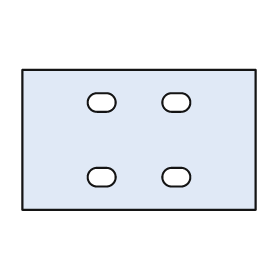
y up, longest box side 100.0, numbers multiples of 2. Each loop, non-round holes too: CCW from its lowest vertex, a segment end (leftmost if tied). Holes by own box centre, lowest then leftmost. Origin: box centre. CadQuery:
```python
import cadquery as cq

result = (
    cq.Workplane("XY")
    .moveTo(-50.0, -30.0)
    .lineTo(50.0, -30.0)
    .lineTo(50.0, 30.0)
    .lineTo(-50.0, 30.0)
    .close()
    .moveTo(-18.0, -20.0)
    .lineTo(-14.0, -20.0)
    .threePointArc((-10.0, -16.0), (-14.0, -12.0))
    .lineTo(-18.0, -12.0)
    .threePointArc((-22.0, -16.0), (-18.0, -20.0))
    .close()
    .moveTo(14.0, -20.0)
    .lineTo(18.0, -20.0)
    .threePointArc((22.0, -16.0), (18.0, -12.0))
    .lineTo(14.0, -12.0)
    .threePointArc((10.0, -16.0), (14.0, -20.0))
    .close()
    .moveTo(-18.0, 12.0)
    .lineTo(-14.0, 12.0)
    .threePointArc((-10.0, 16.0), (-14.0, 20.0))
    .lineTo(-18.0, 20.0)
    .threePointArc((-22.0, 16.0), (-18.0, 12.0))
    .close()
    .moveTo(14.0, 12.0)
    .lineTo(18.0, 12.0)
    .threePointArc((22.0, 16.0), (18.0, 20.0))
    .lineTo(14.0, 20.0)
    .threePointArc((10.0, 16.0), (14.0, 12.0))
    .close()
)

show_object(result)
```